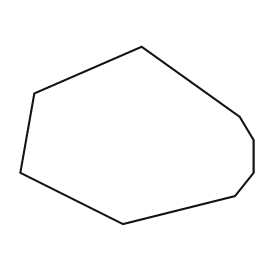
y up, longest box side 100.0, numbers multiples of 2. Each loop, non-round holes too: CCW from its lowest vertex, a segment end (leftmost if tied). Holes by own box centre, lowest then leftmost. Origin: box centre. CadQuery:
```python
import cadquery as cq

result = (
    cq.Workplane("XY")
    .moveTo(-6.0, -38.0)
    .lineTo(42.0, -26.0)
    .lineTo(50.0, -16.0)
    .lineTo(50.0, -2.0)
    .lineTo(44.0, 8.0)
    .lineTo(2.0, 38.0)
    .lineTo(-44.0, 18.0)
    .lineTo(-50.0, -16.0)
    .close()
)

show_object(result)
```